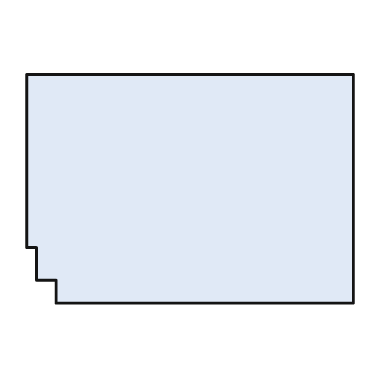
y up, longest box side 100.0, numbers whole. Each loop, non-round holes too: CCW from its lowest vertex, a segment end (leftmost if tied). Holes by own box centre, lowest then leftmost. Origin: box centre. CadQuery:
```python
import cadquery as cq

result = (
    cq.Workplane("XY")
    .moveTo(-41.0, -35.0)
    .lineTo(50.0, -35.0)
    .lineTo(50.0, 35.0)
    .lineTo(-50.0, 35.0)
    .lineTo(-50.0, -18.0)
    .lineTo(-47.0, -18.0)
    .lineTo(-47.0, -28.0)
    .lineTo(-41.0, -28.0)
    .close()
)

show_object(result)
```